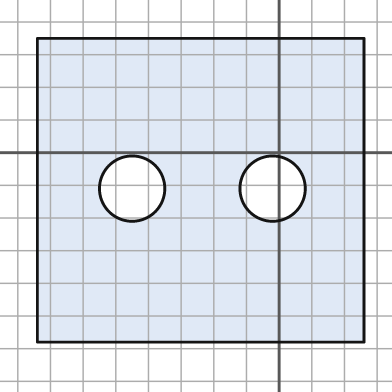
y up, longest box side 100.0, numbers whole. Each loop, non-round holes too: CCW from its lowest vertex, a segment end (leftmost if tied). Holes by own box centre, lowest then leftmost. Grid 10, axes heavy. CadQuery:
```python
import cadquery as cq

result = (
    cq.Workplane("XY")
    .moveTo(-74.0, -58.0)
    .lineTo(26.0, -58.0)
    .lineTo(26.0, 35.0)
    .lineTo(-74.0, 35.0)
    .close()
    .moveTo(-45.0, -11.0)
    .circle(10.0)
    .moveTo(-2.0, -11.0)
    .circle(10.0)
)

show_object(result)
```